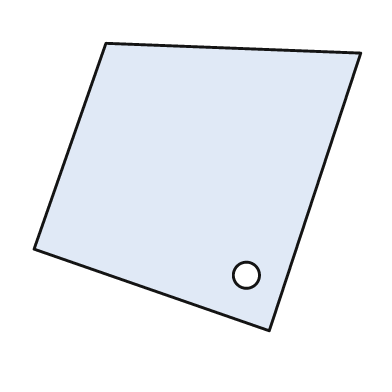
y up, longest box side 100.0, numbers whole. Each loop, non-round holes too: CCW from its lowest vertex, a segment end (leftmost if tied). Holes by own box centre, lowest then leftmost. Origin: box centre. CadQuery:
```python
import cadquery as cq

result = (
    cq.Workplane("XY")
    .moveTo(22.0, -44.0)
    .lineTo(50.0, 41.0)
    .lineTo(-28.0, 44.0)
    .lineTo(-50.0, -19.0)
    .close()
    .moveTo(15.0, -27.0)
    .circle(4.0)
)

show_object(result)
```